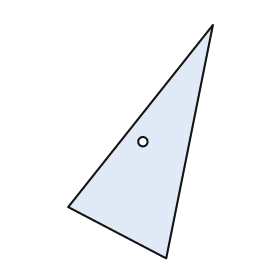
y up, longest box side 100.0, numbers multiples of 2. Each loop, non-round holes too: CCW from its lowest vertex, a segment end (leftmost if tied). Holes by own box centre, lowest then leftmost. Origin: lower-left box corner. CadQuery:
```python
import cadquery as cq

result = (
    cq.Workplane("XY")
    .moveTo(42.0, 0.0)
    .lineTo(62.0, 100.0)
    .lineTo(0.0, 22.0)
    .close()
    .moveTo(32.0, 50.0)
    .circle(2.0)
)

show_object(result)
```